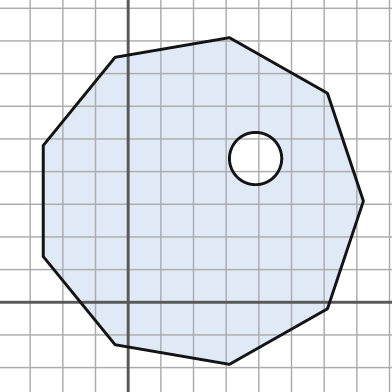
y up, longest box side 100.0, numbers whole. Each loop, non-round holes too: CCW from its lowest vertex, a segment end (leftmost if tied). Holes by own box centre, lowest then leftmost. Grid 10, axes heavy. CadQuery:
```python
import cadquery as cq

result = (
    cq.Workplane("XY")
    .moveTo(31.0, -19.0)
    .lineTo(61.0, -2.0)
    .lineTo(72.0, 31.0)
    .lineTo(61.0, 64.0)
    .lineTo(31.0, 81.0)
    .lineTo(-4.0, 75.0)
    .lineTo(-26.0, 48.0)
    .lineTo(-26.0, 14.0)
    .lineTo(-4.0, -13.0)
    .close()
    .moveTo(39.0, 44.0)
    .circle(8.0)
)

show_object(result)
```